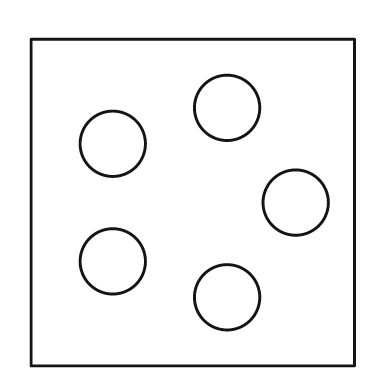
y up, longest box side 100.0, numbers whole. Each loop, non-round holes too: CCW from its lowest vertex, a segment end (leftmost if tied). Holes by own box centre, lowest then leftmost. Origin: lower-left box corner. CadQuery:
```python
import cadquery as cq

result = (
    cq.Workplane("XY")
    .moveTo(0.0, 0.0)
    .lineTo(99.0, 0.0)
    .lineTo(99.0, 100.0)
    .lineTo(0.0, 100.0)
    .close()
    .moveTo(60.0, 21.0)
    .circle(10.0)
    .moveTo(25.0, 32.0)
    .circle(10.0)
    .moveTo(81.0, 50.0)
    .circle(10.0)
    .moveTo(25.0, 68.0)
    .circle(10.0)
    .moveTo(60.0, 79.0)
    .circle(10.0)
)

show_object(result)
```